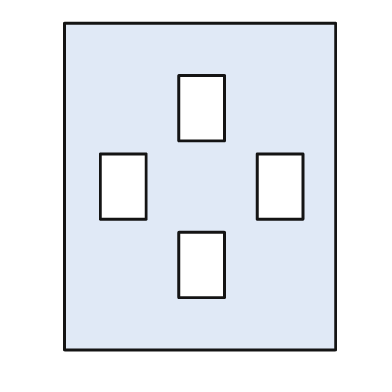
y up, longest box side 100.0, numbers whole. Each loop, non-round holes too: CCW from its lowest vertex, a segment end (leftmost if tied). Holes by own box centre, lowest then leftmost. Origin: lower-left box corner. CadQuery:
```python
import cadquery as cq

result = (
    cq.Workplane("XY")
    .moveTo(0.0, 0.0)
    .lineTo(83.0, 0.0)
    .lineTo(83.0, 100.0)
    .lineTo(0.0, 100.0)
    .close()
    .moveTo(35.0, 16.0)
    .lineTo(49.0, 16.0)
    .lineTo(49.0, 36.0)
    .lineTo(35.0, 36.0)
    .close()
    .moveTo(11.0, 40.0)
    .lineTo(25.0, 40.0)
    .lineTo(25.0, 60.0)
    .lineTo(11.0, 60.0)
    .close()
    .moveTo(59.0, 40.0)
    .lineTo(73.0, 40.0)
    .lineTo(73.0, 60.0)
    .lineTo(59.0, 60.0)
    .close()
    .moveTo(35.0, 64.0)
    .lineTo(49.0, 64.0)
    .lineTo(49.0, 84.0)
    .lineTo(35.0, 84.0)
    .close()
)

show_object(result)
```